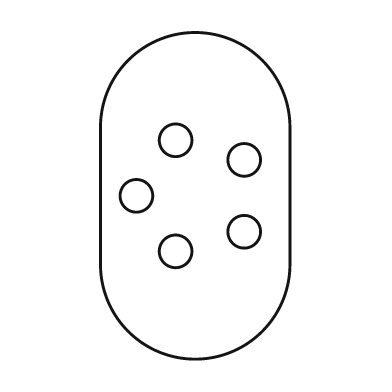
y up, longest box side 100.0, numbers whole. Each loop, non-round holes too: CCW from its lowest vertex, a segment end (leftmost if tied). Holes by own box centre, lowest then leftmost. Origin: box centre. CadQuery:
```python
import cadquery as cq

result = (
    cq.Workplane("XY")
    .moveTo(-29.0, -21.0)
    .threePointArc((0.0, -50.0), (29.0, -21.0))
    .lineTo(29.0, 21.0)
    .threePointArc((0.0, 50.0), (-29.0, 21.0))
    .close()
    .moveTo(-6.0, -17.0)
    .circle(5.0)
    .moveTo(15.0, -11.0)
    .circle(5.0)
    .moveTo(-18.0, 0.0)
    .circle(5.0)
    .moveTo(15.0, 11.0)
    .circle(5.0)
    .moveTo(-6.0, 17.0)
    .circle(5.0)
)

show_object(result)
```